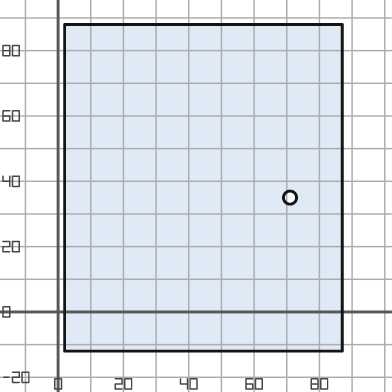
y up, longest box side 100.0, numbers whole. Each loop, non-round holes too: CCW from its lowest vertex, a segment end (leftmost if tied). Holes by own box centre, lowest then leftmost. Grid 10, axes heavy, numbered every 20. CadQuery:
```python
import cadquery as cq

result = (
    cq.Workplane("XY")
    .moveTo(2.0, -12.0)
    .lineTo(87.0, -12.0)
    .lineTo(87.0, 88.0)
    .lineTo(2.0, 88.0)
    .close()
    .moveTo(71.0, 35.0)
    .circle(2.0)
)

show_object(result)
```